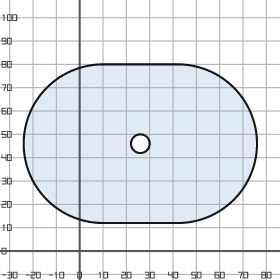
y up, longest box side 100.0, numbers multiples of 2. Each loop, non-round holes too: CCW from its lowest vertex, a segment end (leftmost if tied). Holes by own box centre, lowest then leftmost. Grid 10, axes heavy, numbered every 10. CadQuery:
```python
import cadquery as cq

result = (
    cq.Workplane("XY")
    .moveTo(10.0, 12.0)
    .lineTo(42.0, 12.0)
    .threePointArc((76.0, 46.0), (42.0, 80.0))
    .lineTo(10.0, 80.0)
    .threePointArc((-24.0, 46.0), (10.0, 12.0))
    .close()
    .moveTo(26.0, 46.0)
    .circle(4.0)
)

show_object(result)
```